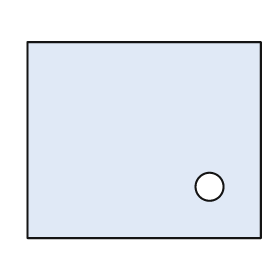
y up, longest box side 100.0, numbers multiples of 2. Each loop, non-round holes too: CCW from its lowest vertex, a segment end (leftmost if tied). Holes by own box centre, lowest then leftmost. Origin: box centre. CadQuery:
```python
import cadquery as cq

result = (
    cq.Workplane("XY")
    .moveTo(-50.0, -42.0)
    .lineTo(50.0, -42.0)
    .lineTo(50.0, 42.0)
    .lineTo(-50.0, 42.0)
    .close()
    .moveTo(28.0, -20.0)
    .circle(6.0)
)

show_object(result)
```